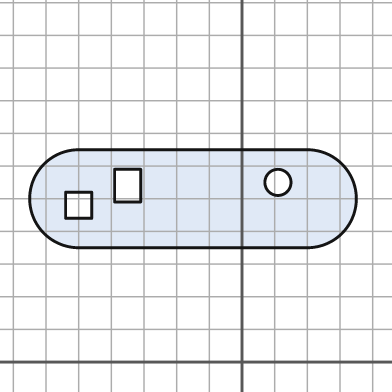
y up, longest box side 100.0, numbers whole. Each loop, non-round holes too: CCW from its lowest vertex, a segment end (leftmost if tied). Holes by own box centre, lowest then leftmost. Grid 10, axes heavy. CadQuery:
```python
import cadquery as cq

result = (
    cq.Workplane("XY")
    .moveTo(-50.0, 35.0)
    .lineTo(20.0, 35.0)
    .threePointArc((35.0, 50.0), (20.0, 65.0))
    .lineTo(-50.0, 65.0)
    .threePointArc((-65.0, 50.0), (-50.0, 35.0))
    .close()
    .moveTo(-54.0, 44.0)
    .lineTo(-46.0, 44.0)
    .lineTo(-46.0, 52.0)
    .lineTo(-54.0, 52.0)
    .close()
    .moveTo(-39.0, 49.0)
    .lineTo(-31.0, 49.0)
    .lineTo(-31.0, 59.0)
    .lineTo(-39.0, 59.0)
    .close()
    .moveTo(11.0, 55.0)
    .circle(4.0)
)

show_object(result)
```